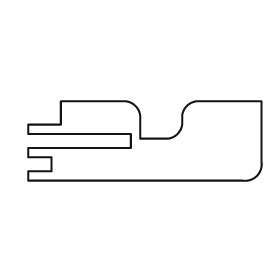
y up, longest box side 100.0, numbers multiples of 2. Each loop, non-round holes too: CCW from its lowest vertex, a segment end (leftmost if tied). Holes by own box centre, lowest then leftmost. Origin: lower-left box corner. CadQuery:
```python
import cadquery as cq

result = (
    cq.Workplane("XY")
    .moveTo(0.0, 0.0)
    .lineTo(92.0, 0.0)
    .threePointArc((98.0, 2.0), (100.0, 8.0))
    .lineTo(100.0, 34.0)
    .lineTo(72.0, 34.0)
    .threePointArc((68.0, 32.0), (66.0, 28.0))
    .lineTo(66.0, 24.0)
    .threePointArc((64.0, 20.0), (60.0, 18.0))
    .lineTo(48.0, 18.0)
    .lineTo(48.0, 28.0)
    .threePointArc((46.0, 32.0), (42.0, 34.0))
    .lineTo(14.0, 34.0)
    .lineTo(14.0, 24.0)
    .lineTo(0.0, 24.0)
    .lineTo(0.0, 20.0)
    .lineTo(44.0, 20.0)
    .lineTo(44.0, 14.0)
    .lineTo(0.0, 14.0)
    .lineTo(0.0, 10.0)
    .lineTo(10.0, 10.0)
    .lineTo(10.0, 4.0)
    .lineTo(0.0, 4.0)
    .close()
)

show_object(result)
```